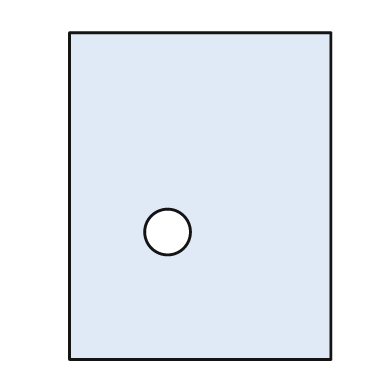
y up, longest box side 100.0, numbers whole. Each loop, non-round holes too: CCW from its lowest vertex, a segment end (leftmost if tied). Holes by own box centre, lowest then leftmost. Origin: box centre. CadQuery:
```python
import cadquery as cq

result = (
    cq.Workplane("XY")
    .moveTo(-40.0, -50.0)
    .lineTo(40.0, -50.0)
    .lineTo(40.0, 50.0)
    .lineTo(-40.0, 50.0)
    .close()
    .moveTo(-10.0, -11.0)
    .circle(7.0)
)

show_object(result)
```